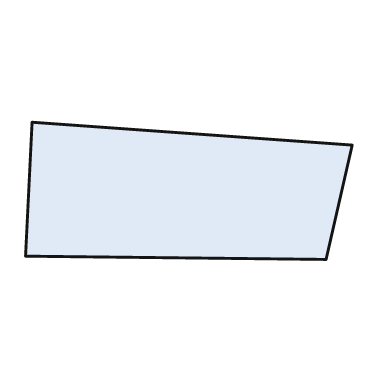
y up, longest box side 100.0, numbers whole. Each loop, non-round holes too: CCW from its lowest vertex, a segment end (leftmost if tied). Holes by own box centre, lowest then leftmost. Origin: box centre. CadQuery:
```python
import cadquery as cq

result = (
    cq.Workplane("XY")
    .moveTo(42.0, -21.0)
    .lineTo(50.0, 14.0)
    .lineTo(-48.0, 21.0)
    .lineTo(-50.0, -20.0)
    .close()
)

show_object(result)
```